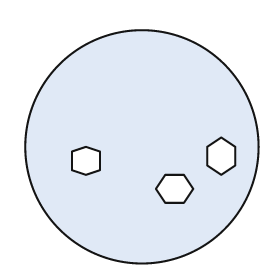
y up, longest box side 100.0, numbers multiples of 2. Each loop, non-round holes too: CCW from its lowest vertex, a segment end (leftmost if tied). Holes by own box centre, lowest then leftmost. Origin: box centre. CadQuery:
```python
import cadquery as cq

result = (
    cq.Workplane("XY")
    .moveTo(0.0, 0.0)
    .circle(50.0)
    .moveTo(10.0, -24.0)
    .lineTo(18.0, -24.0)
    .lineTo(22.0, -18.0)
    .lineTo(18.0, -12.0)
    .lineTo(10.0, -12.0)
    .lineTo(6.0, -18.0)
    .close()
    .moveTo(-24.0, -12.0)
    .lineTo(-18.0, -10.0)
    .lineTo(-18.0, -2.0)
    .lineTo(-24.0, 0.0)
    .lineTo(-30.0, -2.0)
    .lineTo(-30.0, -10.0)
    .close()
    .moveTo(34.0, -12.0)
    .lineTo(40.0, -8.0)
    .lineTo(40.0, 0.0)
    .lineTo(34.0, 4.0)
    .lineTo(28.0, 0.0)
    .lineTo(28.0, -8.0)
    .close()
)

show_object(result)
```